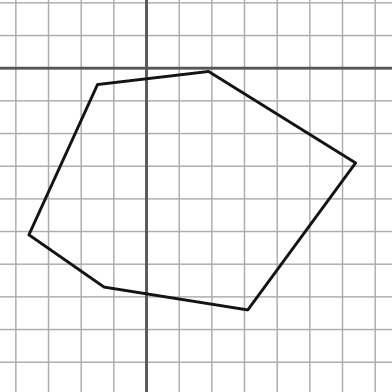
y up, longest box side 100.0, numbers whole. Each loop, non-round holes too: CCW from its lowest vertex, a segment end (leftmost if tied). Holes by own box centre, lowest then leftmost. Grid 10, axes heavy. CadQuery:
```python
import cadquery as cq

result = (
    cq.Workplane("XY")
    .moveTo(31.0, -74.0)
    .lineTo(64.0, -29.0)
    .lineTo(19.0, -1.0)
    .lineTo(-15.0, -5.0)
    .lineTo(-36.0, -51.0)
    .lineTo(-13.0, -67.0)
    .close()
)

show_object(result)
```